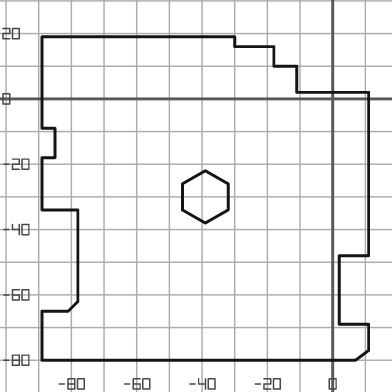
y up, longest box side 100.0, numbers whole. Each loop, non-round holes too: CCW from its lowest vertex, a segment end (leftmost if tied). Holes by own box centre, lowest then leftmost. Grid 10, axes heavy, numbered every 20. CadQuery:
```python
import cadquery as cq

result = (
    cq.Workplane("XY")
    .moveTo(-89.0, -80.0)
    .lineTo(7.0, -80.0)
    .lineTo(11.0, -77.0)
    .lineTo(11.0, -69.0)
    .lineTo(2.0, -69.0)
    .lineTo(2.0, -48.0)
    .lineTo(11.0, -48.0)
    .lineTo(11.0, 2.0)
    .lineTo(-11.0, 2.0)
    .lineTo(-11.0, 10.0)
    .lineTo(-18.0, 10.0)
    .lineTo(-18.0, 16.0)
    .lineTo(-30.0, 16.0)
    .lineTo(-30.0, 19.0)
    .lineTo(-89.0, 19.0)
    .lineTo(-89.0, -9.0)
    .lineTo(-85.0, -9.0)
    .lineTo(-85.0, -18.0)
    .lineTo(-89.0, -18.0)
    .lineTo(-89.0, -34.0)
    .lineTo(-78.0, -34.0)
    .lineTo(-78.0, -62.0)
    .lineTo(-81.0, -65.0)
    .lineTo(-89.0, -65.0)
    .close()
    .moveTo(-39.0, -38.0)
    .lineTo(-32.0, -34.0)
    .lineTo(-32.0, -26.0)
    .lineTo(-39.0, -22.0)
    .lineTo(-46.0, -26.0)
    .lineTo(-46.0, -34.0)
    .close()
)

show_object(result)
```